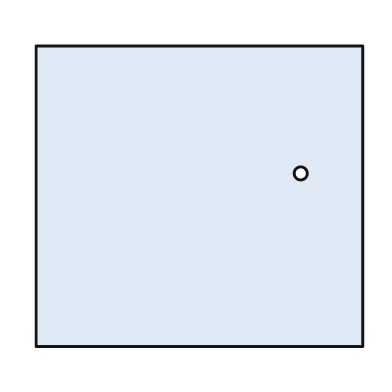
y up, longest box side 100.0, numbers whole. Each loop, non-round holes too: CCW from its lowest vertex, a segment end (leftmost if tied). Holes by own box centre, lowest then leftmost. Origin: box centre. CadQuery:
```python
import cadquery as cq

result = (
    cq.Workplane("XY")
    .moveTo(-50.0, -46.0)
    .lineTo(50.0, -46.0)
    .lineTo(50.0, 46.0)
    .lineTo(-50.0, 46.0)
    .close()
    .moveTo(31.0, 7.0)
    .circle(2.0)
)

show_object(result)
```